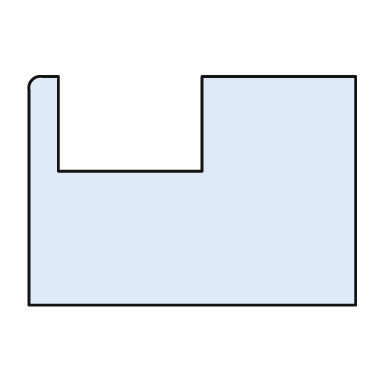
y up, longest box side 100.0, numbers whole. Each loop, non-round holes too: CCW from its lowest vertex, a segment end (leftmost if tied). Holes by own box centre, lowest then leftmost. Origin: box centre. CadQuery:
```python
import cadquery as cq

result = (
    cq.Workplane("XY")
    .moveTo(-50.0, -35.0)
    .lineTo(50.0, -35.0)
    .lineTo(50.0, 35.0)
    .lineTo(3.0, 35.0)
    .lineTo(3.0, 6.0)
    .lineTo(-41.0, 6.0)
    .lineTo(-41.0, 35.0)
    .lineTo(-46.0, 35.0)
    .threePointArc((-49.0, 34.0), (-50.0, 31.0))
    .close()
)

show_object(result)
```